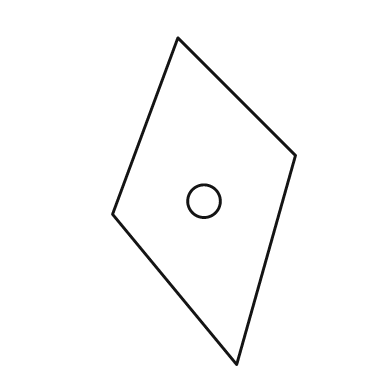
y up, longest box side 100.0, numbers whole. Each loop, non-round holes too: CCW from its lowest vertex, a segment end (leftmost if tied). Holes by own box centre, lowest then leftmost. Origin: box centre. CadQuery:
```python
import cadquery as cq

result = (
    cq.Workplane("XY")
    .moveTo(10.0, -50.0)
    .lineTo(28.0, 14.0)
    .lineTo(-8.0, 50.0)
    .lineTo(-28.0, -4.0)
    .close()
    .moveTo(0.0, 0.0)
    .circle(5.0)
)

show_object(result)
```